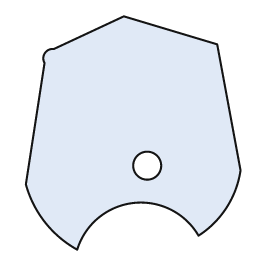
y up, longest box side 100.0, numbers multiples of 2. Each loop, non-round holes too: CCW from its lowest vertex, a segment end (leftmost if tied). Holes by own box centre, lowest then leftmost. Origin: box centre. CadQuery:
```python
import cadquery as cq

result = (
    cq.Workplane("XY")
    .moveTo(-24.0, -50.0)
    .threePointArc((0.0, -30.0), (28.0, -44.0))
    .threePointArc((40.0, -32.0), (46.0, -16.0))
    .lineTo(36.0, 38.0)
    .lineTo(-4.0, 50.0)
    .lineTo(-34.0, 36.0)
    .threePointArc((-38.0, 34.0), (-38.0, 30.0))
    .lineTo(-46.0, -22.0)
    .threePointArc((-38.0, -38.0), (-24.0, -50.0))
    .close()
    .moveTo(6.0, -14.0)
    .circle(6.0)
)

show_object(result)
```